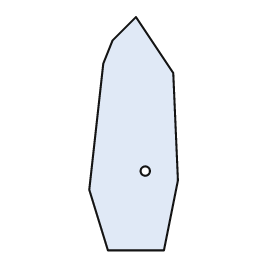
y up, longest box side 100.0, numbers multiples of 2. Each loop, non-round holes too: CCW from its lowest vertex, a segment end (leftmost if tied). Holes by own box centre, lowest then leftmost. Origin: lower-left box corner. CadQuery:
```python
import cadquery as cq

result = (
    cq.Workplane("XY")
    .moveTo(8.0, 0.0)
    .lineTo(32.0, 0.0)
    .lineTo(38.0, 30.0)
    .lineTo(36.0, 76.0)
    .lineTo(20.0, 100.0)
    .lineTo(10.0, 90.0)
    .lineTo(6.0, 80.0)
    .lineTo(0.0, 26.0)
    .close()
    .moveTo(24.0, 34.0)
    .circle(2.0)
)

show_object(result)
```